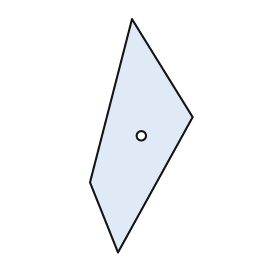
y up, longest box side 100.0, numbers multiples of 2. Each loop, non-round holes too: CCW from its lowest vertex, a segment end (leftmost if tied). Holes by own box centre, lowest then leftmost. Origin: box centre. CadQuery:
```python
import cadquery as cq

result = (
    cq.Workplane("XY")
    .moveTo(-10.0, -50.0)
    .lineTo(22.0, 8.0)
    .lineTo(-4.0, 50.0)
    .lineTo(-22.0, -20.0)
    .close()
    .moveTo(0.0, 0.0)
    .circle(2.0)
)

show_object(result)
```